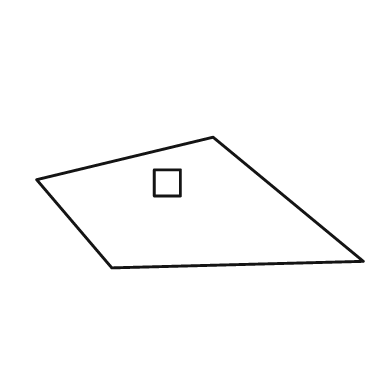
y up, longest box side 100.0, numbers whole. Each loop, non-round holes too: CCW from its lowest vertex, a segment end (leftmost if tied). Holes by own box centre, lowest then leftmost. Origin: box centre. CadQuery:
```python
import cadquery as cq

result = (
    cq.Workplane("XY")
    .moveTo(-27.0, -20.0)
    .lineTo(50.0, -18.0)
    .lineTo(4.0, 20.0)
    .lineTo(-50.0, 7.0)
    .close()
    .moveTo(-14.0, 2.0)
    .lineTo(-6.0, 2.0)
    .lineTo(-6.0, 10.0)
    .lineTo(-14.0, 10.0)
    .close()
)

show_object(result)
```